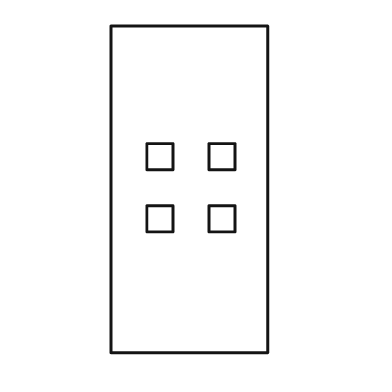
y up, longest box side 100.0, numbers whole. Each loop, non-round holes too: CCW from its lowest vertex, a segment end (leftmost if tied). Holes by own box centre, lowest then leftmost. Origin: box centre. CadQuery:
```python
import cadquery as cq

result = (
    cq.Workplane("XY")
    .moveTo(-24.0, -50.0)
    .lineTo(24.0, -50.0)
    .lineTo(24.0, 50.0)
    .lineTo(-24.0, 50.0)
    .close()
    .moveTo(-13.0, -13.0)
    .lineTo(-5.0, -13.0)
    .lineTo(-5.0, -5.0)
    .lineTo(-13.0, -5.0)
    .close()
    .moveTo(6.0, -13.0)
    .lineTo(14.0, -13.0)
    .lineTo(14.0, -5.0)
    .lineTo(6.0, -5.0)
    .close()
    .moveTo(-13.0, 6.0)
    .lineTo(-5.0, 6.0)
    .lineTo(-5.0, 14.0)
    .lineTo(-13.0, 14.0)
    .close()
    .moveTo(6.0, 6.0)
    .lineTo(14.0, 6.0)
    .lineTo(14.0, 14.0)
    .lineTo(6.0, 14.0)
    .close()
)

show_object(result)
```